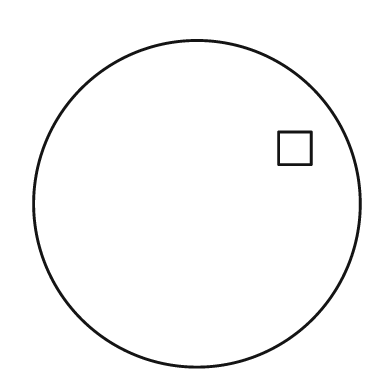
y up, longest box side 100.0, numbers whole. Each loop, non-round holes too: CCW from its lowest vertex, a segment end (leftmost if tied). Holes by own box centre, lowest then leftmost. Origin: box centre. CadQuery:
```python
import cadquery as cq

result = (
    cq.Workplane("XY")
    .moveTo(0.0, 0.0)
    .circle(50.0)
    .moveTo(25.0, 12.0)
    .lineTo(35.0, 12.0)
    .lineTo(35.0, 22.0)
    .lineTo(25.0, 22.0)
    .close()
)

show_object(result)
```